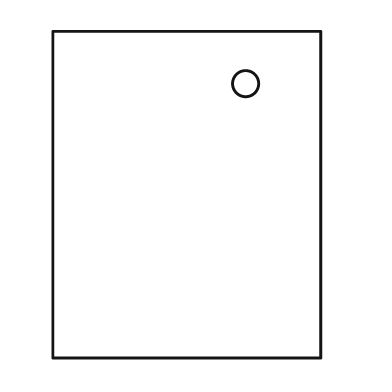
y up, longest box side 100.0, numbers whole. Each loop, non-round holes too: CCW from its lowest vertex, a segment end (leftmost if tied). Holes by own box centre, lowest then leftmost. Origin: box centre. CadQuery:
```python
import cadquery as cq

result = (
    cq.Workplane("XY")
    .moveTo(-41.0, -50.0)
    .lineTo(41.0, -50.0)
    .lineTo(41.0, 50.0)
    .lineTo(-41.0, 50.0)
    .close()
    .moveTo(18.0, 34.0)
    .circle(4.0)
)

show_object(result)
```